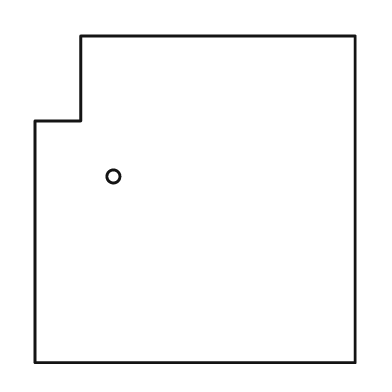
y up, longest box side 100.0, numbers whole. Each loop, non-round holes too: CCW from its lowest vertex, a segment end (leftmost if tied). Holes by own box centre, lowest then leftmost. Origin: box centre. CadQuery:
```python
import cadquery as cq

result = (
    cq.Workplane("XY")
    .moveTo(-49.0, -50.0)
    .lineTo(49.0, -50.0)
    .lineTo(49.0, 50.0)
    .lineTo(-35.0, 50.0)
    .lineTo(-35.0, 24.0)
    .lineTo(-49.0, 24.0)
    .close()
    .moveTo(-25.0, 7.0)
    .circle(2.0)
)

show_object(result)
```